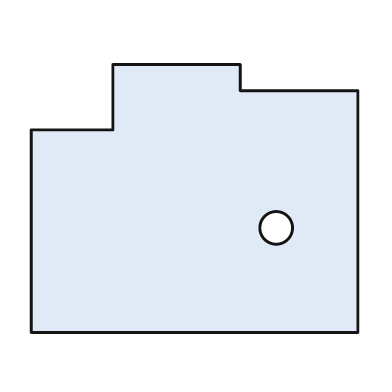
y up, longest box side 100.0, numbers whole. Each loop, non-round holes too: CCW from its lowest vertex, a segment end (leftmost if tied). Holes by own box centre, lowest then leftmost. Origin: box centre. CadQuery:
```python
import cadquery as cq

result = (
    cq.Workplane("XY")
    .moveTo(-50.0, -41.0)
    .lineTo(50.0, -41.0)
    .lineTo(50.0, 33.0)
    .lineTo(14.0, 33.0)
    .lineTo(14.0, 41.0)
    .lineTo(-25.0, 41.0)
    .lineTo(-25.0, 21.0)
    .lineTo(-50.0, 21.0)
    .close()
    .moveTo(25.0, -9.0)
    .circle(5.0)
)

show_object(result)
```